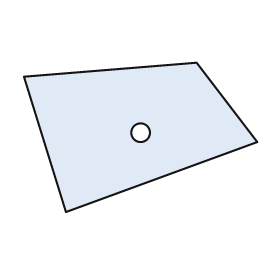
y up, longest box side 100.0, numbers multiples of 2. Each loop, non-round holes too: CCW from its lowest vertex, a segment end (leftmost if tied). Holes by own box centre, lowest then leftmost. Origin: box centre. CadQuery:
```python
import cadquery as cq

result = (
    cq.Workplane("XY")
    .moveTo(-32.0, -32.0)
    .lineTo(50.0, -2.0)
    .lineTo(24.0, 32.0)
    .lineTo(-50.0, 26.0)
    .close()
    .moveTo(0.0, 2.0)
    .circle(4.0)
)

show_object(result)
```